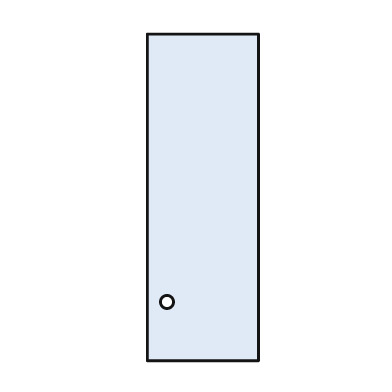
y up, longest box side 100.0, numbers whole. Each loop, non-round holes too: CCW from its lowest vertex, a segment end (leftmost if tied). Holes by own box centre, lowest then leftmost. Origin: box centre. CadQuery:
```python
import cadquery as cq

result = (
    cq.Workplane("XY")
    .moveTo(-17.0, -50.0)
    .lineTo(17.0, -50.0)
    .lineTo(17.0, 50.0)
    .lineTo(-17.0, 50.0)
    .close()
    .moveTo(-11.0, -32.0)
    .circle(2.0)
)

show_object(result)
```